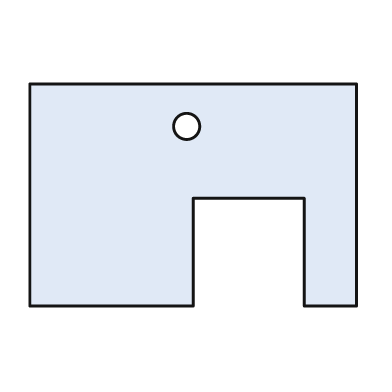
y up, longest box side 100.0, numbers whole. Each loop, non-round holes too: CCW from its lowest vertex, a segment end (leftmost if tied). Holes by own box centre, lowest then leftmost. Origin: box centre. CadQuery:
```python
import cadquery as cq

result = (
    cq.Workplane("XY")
    .moveTo(-50.0, -34.0)
    .lineTo(0.0, -34.0)
    .lineTo(0.0, -1.0)
    .lineTo(34.0, -1.0)
    .lineTo(34.0, -34.0)
    .lineTo(50.0, -34.0)
    .lineTo(50.0, 34.0)
    .lineTo(-50.0, 34.0)
    .close()
    .moveTo(-2.0, 21.0)
    .circle(4.0)
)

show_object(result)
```